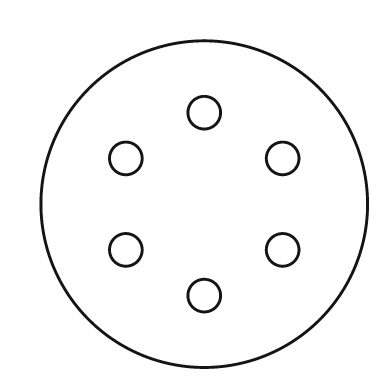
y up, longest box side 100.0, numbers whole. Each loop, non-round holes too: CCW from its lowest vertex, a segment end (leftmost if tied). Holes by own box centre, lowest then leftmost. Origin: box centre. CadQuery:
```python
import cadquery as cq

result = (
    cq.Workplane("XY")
    .moveTo(0.0, 0.0)
    .circle(50.0)
    .moveTo(0.0, -28.0)
    .circle(5.0)
    .moveTo(-24.0, -14.0)
    .circle(5.0)
    .moveTo(24.0, -14.0)
    .circle(5.0)
    .moveTo(-24.0, 14.0)
    .circle(5.0)
    .moveTo(24.0, 14.0)
    .circle(5.0)
    .moveTo(0.0, 28.0)
    .circle(5.0)
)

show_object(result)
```